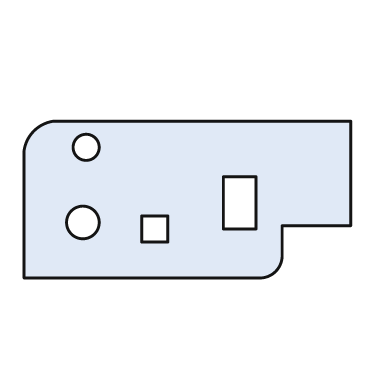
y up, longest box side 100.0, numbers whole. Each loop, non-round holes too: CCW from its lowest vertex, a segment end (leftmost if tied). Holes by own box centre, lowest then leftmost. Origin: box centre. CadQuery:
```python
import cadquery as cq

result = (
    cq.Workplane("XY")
    .moveTo(-50.0, -24.0)
    .lineTo(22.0, -24.0)
    .threePointArc((27.0, -22.0), (29.0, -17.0))
    .lineTo(29.0, -8.0)
    .lineTo(50.0, -8.0)
    .lineTo(50.0, 24.0)
    .lineTo(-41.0, 24.0)
    .threePointArc((-47.0, 21.0), (-50.0, 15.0))
    .close()
    .moveTo(-14.0, -13.0)
    .lineTo(-6.0, -13.0)
    .lineTo(-6.0, -5.0)
    .lineTo(-14.0, -5.0)
    .close()
    .moveTo(-32.0, -7.0)
    .circle(5.0)
    .moveTo(11.0, -9.0)
    .lineTo(21.0, -9.0)
    .lineTo(21.0, 7.0)
    .lineTo(11.0, 7.0)
    .close()
    .moveTo(-31.0, 16.0)
    .circle(4.0)
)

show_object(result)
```